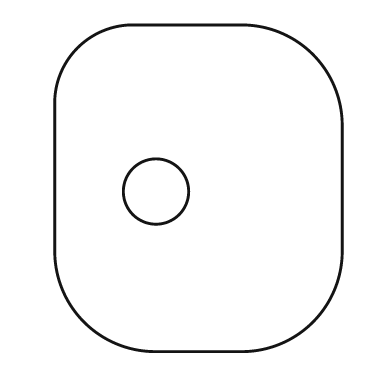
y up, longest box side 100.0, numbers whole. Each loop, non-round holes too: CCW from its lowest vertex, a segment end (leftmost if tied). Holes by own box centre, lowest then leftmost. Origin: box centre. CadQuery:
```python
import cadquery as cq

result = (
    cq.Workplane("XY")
    .moveTo(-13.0, -50.0)
    .lineTo(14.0, -50.0)
    .threePointArc((35.0, -41.0), (44.0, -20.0))
    .lineTo(44.0, 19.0)
    .threePointArc((35.0, 41.0), (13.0, 50.0))
    .lineTo(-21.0, 50.0)
    .threePointArc((-37.0, 43.0), (-44.0, 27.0))
    .lineTo(-44.0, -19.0)
    .threePointArc((-35.0, -41.0), (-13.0, -50.0))
    .close()
    .moveTo(-13.0, -1.0)
    .circle(10.0)
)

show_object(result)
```